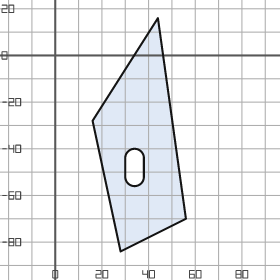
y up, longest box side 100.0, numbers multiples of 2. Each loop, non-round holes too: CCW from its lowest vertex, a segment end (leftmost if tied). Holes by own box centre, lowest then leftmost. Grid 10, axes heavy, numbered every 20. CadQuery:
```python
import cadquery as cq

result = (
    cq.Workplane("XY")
    .moveTo(28.0, -84.0)
    .lineTo(56.0, -70.0)
    .lineTo(44.0, 16.0)
    .lineTo(16.0, -28.0)
    .close()
    .moveTo(30.0, -52.0)
    .threePointArc((34.0, -56.0), (38.0, -52.0))
    .lineTo(38.0, -44.0)
    .threePointArc((34.0, -40.0), (30.0, -44.0))
    .close()
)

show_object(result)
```